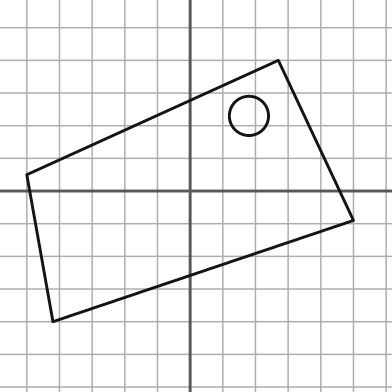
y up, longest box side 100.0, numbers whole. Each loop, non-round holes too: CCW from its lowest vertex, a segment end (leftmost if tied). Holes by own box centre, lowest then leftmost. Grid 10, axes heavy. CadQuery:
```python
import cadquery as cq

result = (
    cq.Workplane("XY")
    .moveTo(-42.0, -40.0)
    .lineTo(50.0, -9.0)
    .lineTo(27.0, 40.0)
    .lineTo(-50.0, 5.0)
    .close()
    .moveTo(18.0, 23.0)
    .circle(6.0)
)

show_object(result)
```